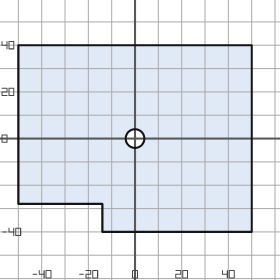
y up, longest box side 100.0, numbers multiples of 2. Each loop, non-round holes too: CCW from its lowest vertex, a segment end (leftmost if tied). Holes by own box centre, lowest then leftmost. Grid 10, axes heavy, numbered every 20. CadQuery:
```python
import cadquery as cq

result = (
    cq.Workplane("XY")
    .moveTo(-14.0, -40.0)
    .lineTo(50.0, -40.0)
    .lineTo(50.0, 40.0)
    .lineTo(-50.0, 40.0)
    .lineTo(-50.0, -28.0)
    .lineTo(-14.0, -28.0)
    .close()
    .moveTo(0.0, 0.0)
    .circle(4.0)
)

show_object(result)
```